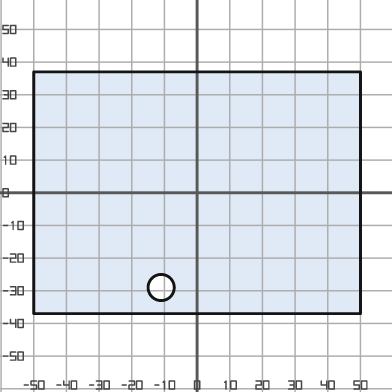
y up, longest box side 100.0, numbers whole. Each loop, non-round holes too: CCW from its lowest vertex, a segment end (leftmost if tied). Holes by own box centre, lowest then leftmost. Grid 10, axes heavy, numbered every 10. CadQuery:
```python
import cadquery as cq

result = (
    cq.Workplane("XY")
    .moveTo(-50.0, -37.0)
    .lineTo(50.0, -37.0)
    .lineTo(50.0, 37.0)
    .lineTo(-50.0, 37.0)
    .close()
    .moveTo(-11.0, -29.0)
    .circle(4.0)
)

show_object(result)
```